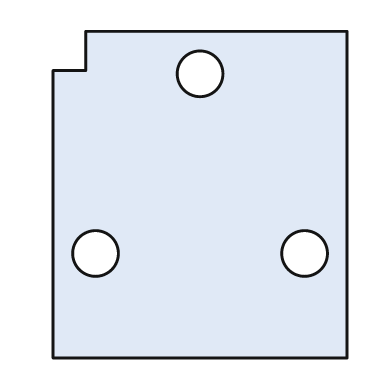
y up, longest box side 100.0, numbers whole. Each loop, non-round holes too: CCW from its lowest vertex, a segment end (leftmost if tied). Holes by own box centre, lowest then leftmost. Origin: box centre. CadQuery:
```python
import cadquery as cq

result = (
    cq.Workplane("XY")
    .moveTo(-45.0, -50.0)
    .lineTo(45.0, -50.0)
    .lineTo(45.0, 50.0)
    .lineTo(-35.0, 50.0)
    .lineTo(-35.0, 38.0)
    .lineTo(-45.0, 38.0)
    .close()
    .moveTo(-32.0, -18.0)
    .circle(7.0)
    .moveTo(32.0, -18.0)
    .circle(7.0)
    .moveTo(0.0, 37.0)
    .circle(7.0)
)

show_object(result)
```